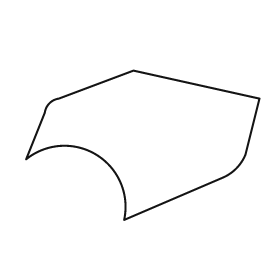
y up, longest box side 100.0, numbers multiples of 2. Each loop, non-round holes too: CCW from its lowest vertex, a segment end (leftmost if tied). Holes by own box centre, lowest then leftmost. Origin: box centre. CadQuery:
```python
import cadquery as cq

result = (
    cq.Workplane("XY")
    .moveTo(-8.0, -32.0)
    .lineTo(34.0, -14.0)
    .threePointArc((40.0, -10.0), (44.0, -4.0))
    .lineTo(50.0, 20.0)
    .lineTo(-4.0, 32.0)
    .lineTo(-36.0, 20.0)
    .threePointArc((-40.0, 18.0), (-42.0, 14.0))
    .lineTo(-50.0, -6.0)
    .threePointArc((-20.0, -4.0), (-8.0, -32.0))
    .close()
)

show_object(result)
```